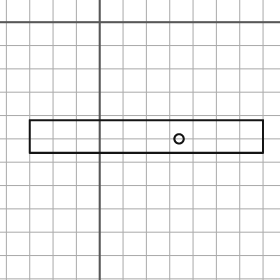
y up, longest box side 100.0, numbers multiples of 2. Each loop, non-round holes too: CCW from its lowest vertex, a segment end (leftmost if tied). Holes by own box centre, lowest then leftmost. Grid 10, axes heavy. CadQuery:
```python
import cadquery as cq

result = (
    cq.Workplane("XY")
    .moveTo(-30.0, -56.0)
    .lineTo(70.0, -56.0)
    .lineTo(70.0, -42.0)
    .lineTo(-30.0, -42.0)
    .close()
    .moveTo(34.0, -50.0)
    .circle(2.0)
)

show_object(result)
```